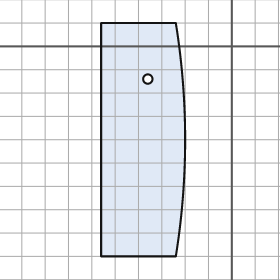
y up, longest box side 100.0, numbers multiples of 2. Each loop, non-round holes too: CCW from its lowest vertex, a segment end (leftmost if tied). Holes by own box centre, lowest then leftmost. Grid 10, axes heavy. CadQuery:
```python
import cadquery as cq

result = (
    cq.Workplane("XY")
    .moveTo(-56.0, -90.0)
    .lineTo(-24.0, -90.0)
    .threePointArc((-20.0, -40.0), (-24.0, 10.0))
    .lineTo(-56.0, 10.0)
    .close()
    .moveTo(-36.0, -14.0)
    .circle(2.0)
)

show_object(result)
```